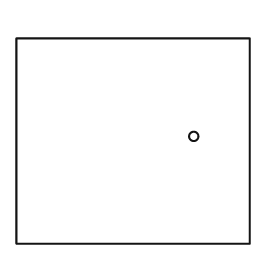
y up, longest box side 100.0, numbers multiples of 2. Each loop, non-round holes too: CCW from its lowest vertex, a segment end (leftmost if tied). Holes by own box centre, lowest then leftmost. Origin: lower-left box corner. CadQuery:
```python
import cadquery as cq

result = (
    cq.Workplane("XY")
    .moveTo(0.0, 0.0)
    .lineTo(100.0, 0.0)
    .lineTo(100.0, 88.0)
    .lineTo(0.0, 88.0)
    .close()
    .moveTo(76.0, 46.0)
    .circle(2.0)
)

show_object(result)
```